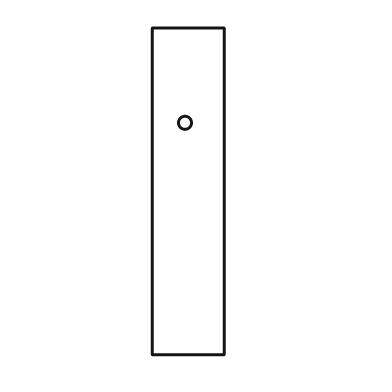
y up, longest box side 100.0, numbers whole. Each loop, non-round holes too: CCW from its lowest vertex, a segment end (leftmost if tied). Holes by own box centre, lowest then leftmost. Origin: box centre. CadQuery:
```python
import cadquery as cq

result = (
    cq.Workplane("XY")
    .moveTo(-11.0, -50.0)
    .lineTo(11.0, -50.0)
    .lineTo(11.0, 50.0)
    .lineTo(-11.0, 50.0)
    .close()
    .moveTo(-1.0, 21.0)
    .circle(2.0)
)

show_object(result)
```